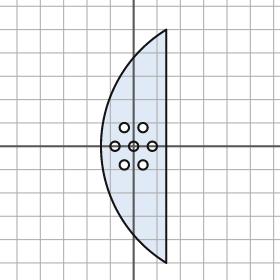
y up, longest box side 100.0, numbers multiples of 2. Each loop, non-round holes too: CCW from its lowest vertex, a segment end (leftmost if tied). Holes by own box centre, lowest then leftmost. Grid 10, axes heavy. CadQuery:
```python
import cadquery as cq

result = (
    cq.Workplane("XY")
    .moveTo(14.0, -50.0)
    .lineTo(14.0, 50.0)
    .threePointArc((-14.0, 0.0), (14.0, -50.0))
    .close()
    .moveTo(-4.0, -8.0)
    .circle(2.0)
    .moveTo(4.0, -8.0)
    .circle(2.0)
    .moveTo(-8.0, 0.0)
    .circle(2.0)
    .moveTo(0.0, 0.0)
    .circle(2.0)
    .moveTo(8.0, 0.0)
    .circle(2.0)
    .moveTo(-4.0, 8.0)
    .circle(2.0)
    .moveTo(4.0, 8.0)
    .circle(2.0)
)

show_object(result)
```